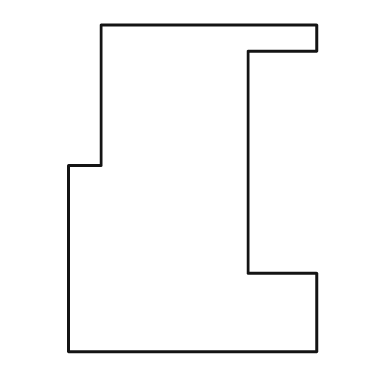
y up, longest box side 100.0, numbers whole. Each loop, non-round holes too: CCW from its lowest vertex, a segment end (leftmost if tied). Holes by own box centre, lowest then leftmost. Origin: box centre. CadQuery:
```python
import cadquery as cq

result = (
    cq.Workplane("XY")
    .moveTo(-38.0, -50.0)
    .lineTo(38.0, -50.0)
    .lineTo(38.0, -26.0)
    .lineTo(17.0, -26.0)
    .lineTo(17.0, 42.0)
    .lineTo(38.0, 42.0)
    .lineTo(38.0, 50.0)
    .lineTo(-28.0, 50.0)
    .lineTo(-28.0, 7.0)
    .lineTo(-38.0, 7.0)
    .close()
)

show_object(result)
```